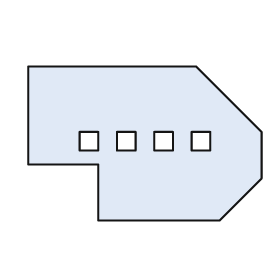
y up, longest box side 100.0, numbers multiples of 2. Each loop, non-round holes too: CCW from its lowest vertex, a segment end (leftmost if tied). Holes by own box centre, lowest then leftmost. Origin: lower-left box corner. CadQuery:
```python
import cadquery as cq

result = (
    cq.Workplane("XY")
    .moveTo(30.0, 0.0)
    .lineTo(82.0, 0.0)
    .lineTo(100.0, 18.0)
    .lineTo(100.0, 38.0)
    .lineTo(72.0, 66.0)
    .lineTo(0.0, 66.0)
    .lineTo(0.0, 24.0)
    .lineTo(30.0, 24.0)
    .close()
    .moveTo(22.0, 30.0)
    .lineTo(30.0, 30.0)
    .lineTo(30.0, 38.0)
    .lineTo(22.0, 38.0)
    .close()
    .moveTo(38.0, 30.0)
    .lineTo(46.0, 30.0)
    .lineTo(46.0, 38.0)
    .lineTo(38.0, 38.0)
    .close()
    .moveTo(54.0, 30.0)
    .lineTo(62.0, 30.0)
    .lineTo(62.0, 38.0)
    .lineTo(54.0, 38.0)
    .close()
    .moveTo(70.0, 30.0)
    .lineTo(78.0, 30.0)
    .lineTo(78.0, 38.0)
    .lineTo(70.0, 38.0)
    .close()
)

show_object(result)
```